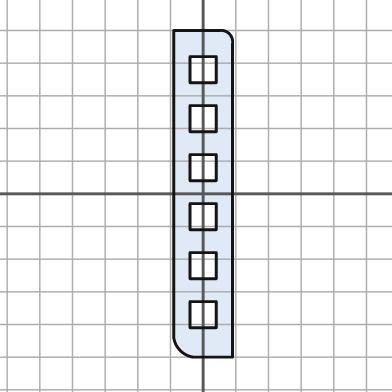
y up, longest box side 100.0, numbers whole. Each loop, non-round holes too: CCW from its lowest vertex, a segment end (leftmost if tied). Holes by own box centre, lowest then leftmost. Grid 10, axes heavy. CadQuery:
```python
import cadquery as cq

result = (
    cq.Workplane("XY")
    .moveTo(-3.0, -50.0)
    .lineTo(9.0, -50.0)
    .lineTo(9.0, 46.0)
    .threePointArc((8.0, 49.0), (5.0, 50.0))
    .lineTo(-9.0, 50.0)
    .lineTo(-9.0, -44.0)
    .threePointArc((-7.0, -48.0), (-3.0, -50.0))
    .close()
    .moveTo(-4.0, -41.0)
    .lineTo(4.0, -41.0)
    .lineTo(4.0, -33.0)
    .lineTo(-4.0, -33.0)
    .close()
    .moveTo(-4.0, -26.0)
    .lineTo(4.0, -26.0)
    .lineTo(4.0, -18.0)
    .lineTo(-4.0, -18.0)
    .close()
    .moveTo(-4.0, -11.0)
    .lineTo(4.0, -11.0)
    .lineTo(4.0, -3.0)
    .lineTo(-4.0, -3.0)
    .close()
    .moveTo(-4.0, 4.0)
    .lineTo(4.0, 4.0)
    .lineTo(4.0, 12.0)
    .lineTo(-4.0, 12.0)
    .close()
    .moveTo(-4.0, 19.0)
    .lineTo(4.0, 19.0)
    .lineTo(4.0, 27.0)
    .lineTo(-4.0, 27.0)
    .close()
    .moveTo(-4.0, 34.0)
    .lineTo(4.0, 34.0)
    .lineTo(4.0, 42.0)
    .lineTo(-4.0, 42.0)
    .close()
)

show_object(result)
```